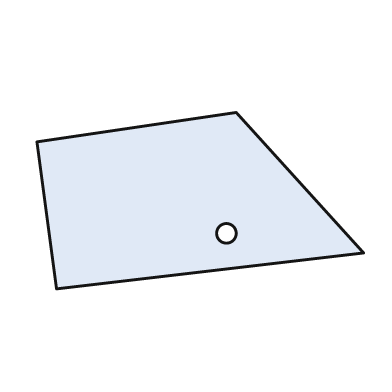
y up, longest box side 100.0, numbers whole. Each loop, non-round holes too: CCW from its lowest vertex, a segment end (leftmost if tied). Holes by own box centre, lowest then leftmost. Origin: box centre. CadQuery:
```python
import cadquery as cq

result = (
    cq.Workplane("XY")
    .moveTo(-44.0, -27.0)
    .lineTo(50.0, -16.0)
    .lineTo(11.0, 27.0)
    .lineTo(-50.0, 18.0)
    .close()
    .moveTo(8.0, -10.0)
    .circle(3.0)
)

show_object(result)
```